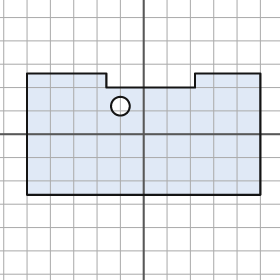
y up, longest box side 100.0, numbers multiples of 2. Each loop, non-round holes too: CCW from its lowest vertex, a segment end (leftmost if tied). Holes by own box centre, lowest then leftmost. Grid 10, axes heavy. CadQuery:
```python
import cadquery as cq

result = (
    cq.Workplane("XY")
    .moveTo(-50.0, -26.0)
    .lineTo(50.0, -26.0)
    .lineTo(50.0, 26.0)
    .lineTo(22.0, 26.0)
    .lineTo(22.0, 20.0)
    .lineTo(-16.0, 20.0)
    .lineTo(-16.0, 26.0)
    .lineTo(-50.0, 26.0)
    .close()
    .moveTo(-10.0, 12.0)
    .circle(4.0)
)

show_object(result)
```